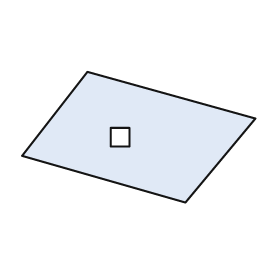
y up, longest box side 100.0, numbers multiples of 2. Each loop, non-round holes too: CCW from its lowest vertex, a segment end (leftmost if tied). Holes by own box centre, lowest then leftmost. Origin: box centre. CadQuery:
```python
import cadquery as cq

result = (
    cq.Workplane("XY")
    .moveTo(20.0, -28.0)
    .lineTo(50.0, 8.0)
    .lineTo(-22.0, 28.0)
    .lineTo(-50.0, -8.0)
    .close()
    .moveTo(-12.0, -4.0)
    .lineTo(-4.0, -4.0)
    .lineTo(-4.0, 4.0)
    .lineTo(-12.0, 4.0)
    .close()
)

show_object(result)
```